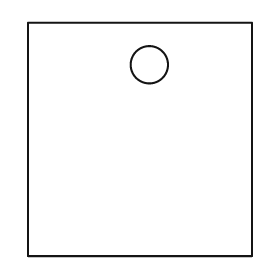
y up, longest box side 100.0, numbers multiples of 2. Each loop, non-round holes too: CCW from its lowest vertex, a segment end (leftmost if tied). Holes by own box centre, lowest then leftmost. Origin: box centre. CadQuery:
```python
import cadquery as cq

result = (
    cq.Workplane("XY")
    .moveTo(-48.0, -50.0)
    .lineTo(48.0, -50.0)
    .lineTo(48.0, 50.0)
    .lineTo(-48.0, 50.0)
    .close()
    .moveTo(4.0, 32.0)
    .circle(8.0)
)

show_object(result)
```